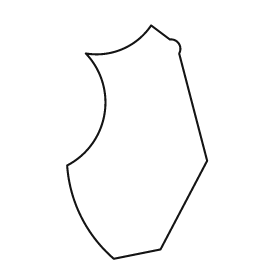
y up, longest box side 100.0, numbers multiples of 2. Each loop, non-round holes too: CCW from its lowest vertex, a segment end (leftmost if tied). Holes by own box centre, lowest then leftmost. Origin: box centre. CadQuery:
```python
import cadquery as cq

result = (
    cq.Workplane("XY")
    .moveTo(-10.0, -50.0)
    .lineTo(10.0, -46.0)
    .lineTo(30.0, -8.0)
    .lineTo(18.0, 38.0)
    .threePointArc((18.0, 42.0), (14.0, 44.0))
    .lineTo(6.0, 50.0)
    .threePointArc((-6.0, 40.0), (-22.0, 38.0))
    .threePointArc((-14.0, 12.0), (-30.0, -10.0))
    .threePointArc((-24.0, -32.0), (-10.0, -50.0))
    .close()
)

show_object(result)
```